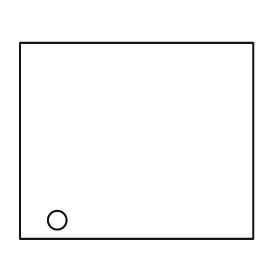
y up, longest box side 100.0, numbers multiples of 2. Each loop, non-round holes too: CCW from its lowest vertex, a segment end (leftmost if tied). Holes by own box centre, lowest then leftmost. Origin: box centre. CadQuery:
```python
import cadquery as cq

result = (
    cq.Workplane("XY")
    .moveTo(-50.0, -42.0)
    .lineTo(50.0, -42.0)
    .lineTo(50.0, 42.0)
    .lineTo(-50.0, 42.0)
    .close()
    .moveTo(-34.0, -34.0)
    .circle(4.0)
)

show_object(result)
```